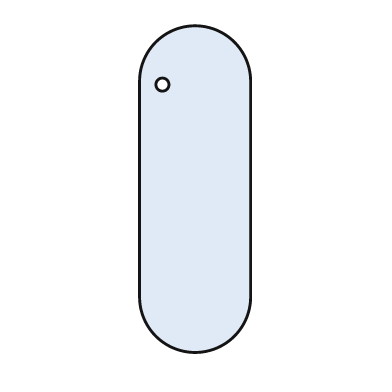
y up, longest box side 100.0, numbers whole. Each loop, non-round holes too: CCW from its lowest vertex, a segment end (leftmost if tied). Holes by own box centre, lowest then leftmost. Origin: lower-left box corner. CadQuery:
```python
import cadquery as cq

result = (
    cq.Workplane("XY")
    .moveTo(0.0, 17.0)
    .threePointArc((17.0, 0.0), (34.0, 17.0))
    .lineTo(34.0, 83.0)
    .threePointArc((17.0, 100.0), (0.0, 83.0))
    .close()
    .moveTo(7.0, 82.0)
    .circle(2.0)
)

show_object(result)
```